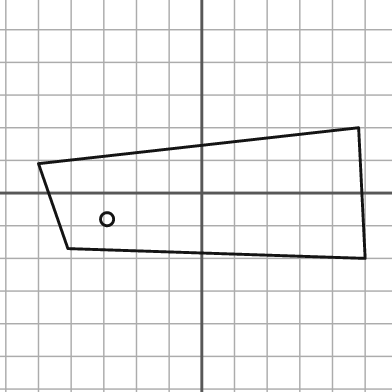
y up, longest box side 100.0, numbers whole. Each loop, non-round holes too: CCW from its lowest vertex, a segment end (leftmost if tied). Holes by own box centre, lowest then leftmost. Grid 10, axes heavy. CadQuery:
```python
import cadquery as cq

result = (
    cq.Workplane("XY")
    .moveTo(50.0, -20.0)
    .lineTo(48.0, 20.0)
    .lineTo(-50.0, 9.0)
    .lineTo(-41.0, -17.0)
    .close()
    .moveTo(-29.0, -8.0)
    .circle(2.0)
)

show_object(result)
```